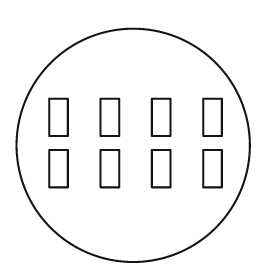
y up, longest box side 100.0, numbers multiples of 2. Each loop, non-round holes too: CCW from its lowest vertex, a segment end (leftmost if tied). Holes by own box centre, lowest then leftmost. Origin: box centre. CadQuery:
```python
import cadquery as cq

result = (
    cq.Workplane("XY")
    .moveTo(0.0, 0.0)
    .circle(50.0)
    .moveTo(-36.0, -18.0)
    .lineTo(-28.0, -18.0)
    .lineTo(-28.0, -2.0)
    .lineTo(-36.0, -2.0)
    .close()
    .moveTo(-14.0, -18.0)
    .lineTo(-6.0, -18.0)
    .lineTo(-6.0, -2.0)
    .lineTo(-14.0, -2.0)
    .close()
    .moveTo(8.0, -18.0)
    .lineTo(16.0, -18.0)
    .lineTo(16.0, -2.0)
    .lineTo(8.0, -2.0)
    .close()
    .moveTo(30.0, -18.0)
    .lineTo(38.0, -18.0)
    .lineTo(38.0, -2.0)
    .lineTo(30.0, -2.0)
    .close()
    .moveTo(-36.0, 4.0)
    .lineTo(-28.0, 4.0)
    .lineTo(-28.0, 20.0)
    .lineTo(-36.0, 20.0)
    .close()
    .moveTo(-14.0, 4.0)
    .lineTo(-6.0, 4.0)
    .lineTo(-6.0, 20.0)
    .lineTo(-14.0, 20.0)
    .close()
    .moveTo(8.0, 4.0)
    .lineTo(16.0, 4.0)
    .lineTo(16.0, 20.0)
    .lineTo(8.0, 20.0)
    .close()
    .moveTo(30.0, 4.0)
    .lineTo(38.0, 4.0)
    .lineTo(38.0, 20.0)
    .lineTo(30.0, 20.0)
    .close()
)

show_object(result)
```